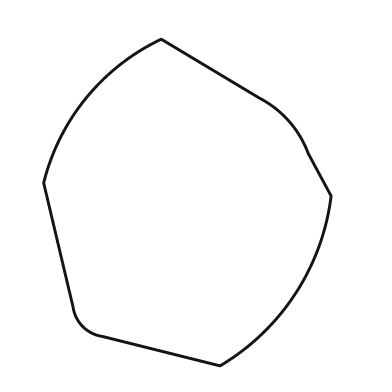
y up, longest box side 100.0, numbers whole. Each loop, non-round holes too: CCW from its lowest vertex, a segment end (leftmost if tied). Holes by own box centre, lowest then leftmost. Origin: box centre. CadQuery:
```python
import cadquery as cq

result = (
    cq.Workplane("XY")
    .moveTo(10.0, -50.0)
    .threePointArc((33.0, -28.0), (44.0, 2.0))
    .lineTo(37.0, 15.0)
    .threePointArc((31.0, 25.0), (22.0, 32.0))
    .lineTo(-8.0, 50.0)
    .threePointArc((-31.0, 32.0), (-44.0, 6.0))
    .lineTo(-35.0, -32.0)
    .threePointArc((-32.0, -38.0), (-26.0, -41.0))
    .close()
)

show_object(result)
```